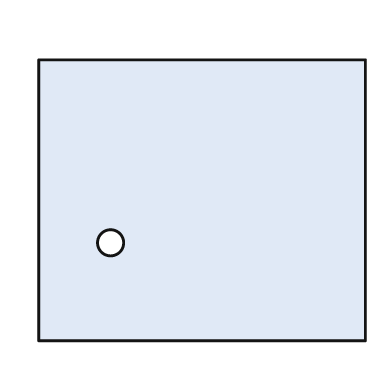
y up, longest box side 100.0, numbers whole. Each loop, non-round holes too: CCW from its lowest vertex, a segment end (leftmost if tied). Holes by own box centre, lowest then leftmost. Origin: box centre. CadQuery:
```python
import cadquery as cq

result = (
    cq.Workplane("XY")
    .moveTo(-50.0, -43.0)
    .lineTo(50.0, -43.0)
    .lineTo(50.0, 43.0)
    .lineTo(-50.0, 43.0)
    .close()
    .moveTo(-28.0, -13.0)
    .circle(4.0)
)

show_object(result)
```